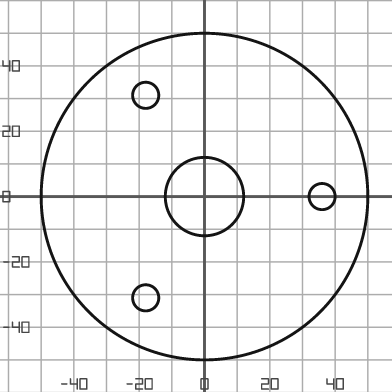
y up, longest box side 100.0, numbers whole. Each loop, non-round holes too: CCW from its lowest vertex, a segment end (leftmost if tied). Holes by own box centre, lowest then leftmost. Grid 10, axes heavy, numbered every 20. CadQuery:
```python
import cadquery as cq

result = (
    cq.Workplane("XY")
    .moveTo(0.0, 0.0)
    .circle(50.0)
    .moveTo(-18.0, -31.0)
    .circle(4.0)
    .moveTo(0.0, 0.0)
    .circle(12.0)
    .moveTo(36.0, 0.0)
    .circle(4.0)
    .moveTo(-18.0, 31.0)
    .circle(4.0)
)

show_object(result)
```